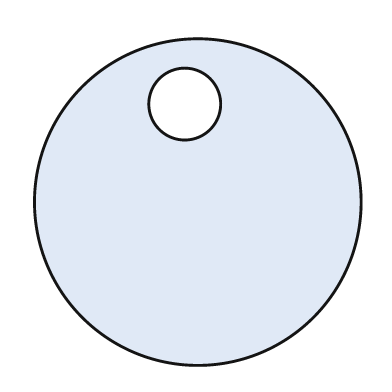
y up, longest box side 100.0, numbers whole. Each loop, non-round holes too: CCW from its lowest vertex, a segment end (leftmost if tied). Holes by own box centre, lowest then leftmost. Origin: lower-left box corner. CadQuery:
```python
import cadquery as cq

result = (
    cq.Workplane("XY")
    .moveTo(50.0, 50.0)
    .circle(50.0)
    .moveTo(46.0, 80.0)
    .circle(11.0)
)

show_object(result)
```